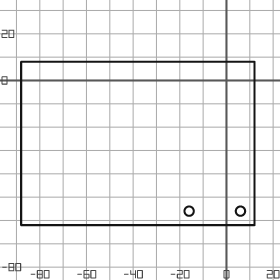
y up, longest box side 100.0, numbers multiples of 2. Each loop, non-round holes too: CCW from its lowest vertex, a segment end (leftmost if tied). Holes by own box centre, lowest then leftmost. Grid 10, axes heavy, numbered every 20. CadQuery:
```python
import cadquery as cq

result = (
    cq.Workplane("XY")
    .moveTo(-88.0, -62.0)
    .lineTo(12.0, -62.0)
    .lineTo(12.0, 8.0)
    .lineTo(-88.0, 8.0)
    .close()
    .moveTo(-16.0, -56.0)
    .circle(2.0)
    .moveTo(6.0, -56.0)
    .circle(2.0)
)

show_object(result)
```